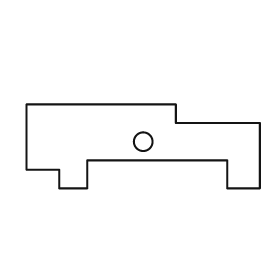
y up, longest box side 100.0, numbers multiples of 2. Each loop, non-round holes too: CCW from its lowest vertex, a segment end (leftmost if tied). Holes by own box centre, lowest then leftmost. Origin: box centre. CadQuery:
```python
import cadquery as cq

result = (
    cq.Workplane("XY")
    .moveTo(-36.0, -18.0)
    .lineTo(-24.0, -18.0)
    .lineTo(-24.0, -6.0)
    .lineTo(36.0, -6.0)
    .lineTo(36.0, -18.0)
    .lineTo(50.0, -18.0)
    .lineTo(50.0, 10.0)
    .lineTo(14.0, 10.0)
    .lineTo(14.0, 18.0)
    .lineTo(-50.0, 18.0)
    .lineTo(-50.0, -10.0)
    .lineTo(-36.0, -10.0)
    .close()
    .moveTo(0.0, 2.0)
    .circle(4.0)
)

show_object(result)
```